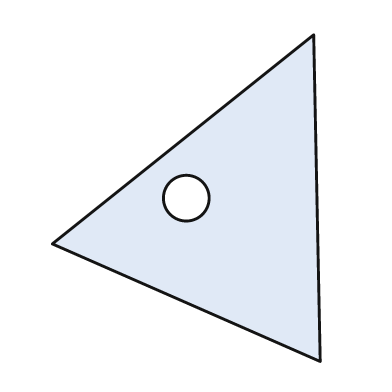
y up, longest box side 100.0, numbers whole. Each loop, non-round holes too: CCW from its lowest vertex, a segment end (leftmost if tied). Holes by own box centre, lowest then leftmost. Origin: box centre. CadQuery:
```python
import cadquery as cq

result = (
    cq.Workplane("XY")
    .moveTo(41.0, -50.0)
    .lineTo(39.0, 50.0)
    .lineTo(-41.0, -14.0)
    .close()
    .moveTo(0.0, 0.0)
    .circle(7.0)
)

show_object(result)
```